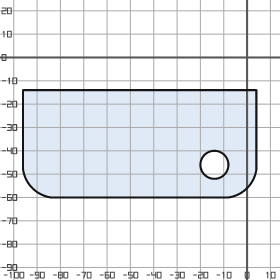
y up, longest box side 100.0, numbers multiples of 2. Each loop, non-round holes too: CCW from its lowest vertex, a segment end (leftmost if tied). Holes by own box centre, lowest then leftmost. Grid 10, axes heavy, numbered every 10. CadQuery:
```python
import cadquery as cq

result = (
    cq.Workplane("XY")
    .moveTo(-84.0, -60.0)
    .lineTo(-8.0, -60.0)
    .threePointArc((0.0, -56.0), (4.0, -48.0))
    .lineTo(4.0, -14.0)
    .lineTo(-96.0, -14.0)
    .lineTo(-96.0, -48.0)
    .threePointArc((-92.0, -56.0), (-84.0, -60.0))
    .close()
    .moveTo(-14.0, -46.0)
    .circle(6.0)
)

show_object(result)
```